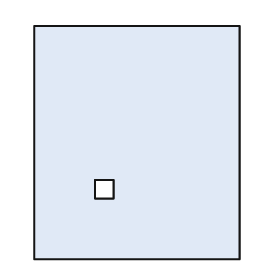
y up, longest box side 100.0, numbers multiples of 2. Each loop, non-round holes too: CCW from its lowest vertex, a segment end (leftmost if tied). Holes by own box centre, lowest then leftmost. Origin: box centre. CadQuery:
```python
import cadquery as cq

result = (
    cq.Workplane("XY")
    .moveTo(-44.0, -50.0)
    .lineTo(44.0, -50.0)
    .lineTo(44.0, 50.0)
    .lineTo(-44.0, 50.0)
    .close()
    .moveTo(-18.0, -24.0)
    .lineTo(-10.0, -24.0)
    .lineTo(-10.0, -16.0)
    .lineTo(-18.0, -16.0)
    .close()
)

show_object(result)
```